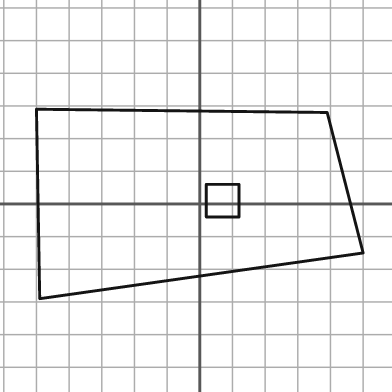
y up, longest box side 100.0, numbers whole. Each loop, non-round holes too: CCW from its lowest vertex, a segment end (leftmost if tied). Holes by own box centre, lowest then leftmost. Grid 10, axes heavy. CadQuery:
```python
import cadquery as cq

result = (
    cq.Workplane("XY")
    .moveTo(-49.0, -29.0)
    .lineTo(50.0, -15.0)
    .lineTo(39.0, 28.0)
    .lineTo(-50.0, 29.0)
    .close()
    .moveTo(2.0, -4.0)
    .lineTo(12.0, -4.0)
    .lineTo(12.0, 6.0)
    .lineTo(2.0, 6.0)
    .close()
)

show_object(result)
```